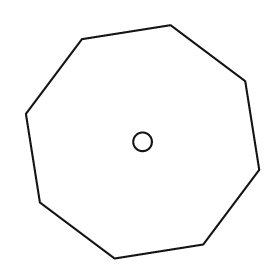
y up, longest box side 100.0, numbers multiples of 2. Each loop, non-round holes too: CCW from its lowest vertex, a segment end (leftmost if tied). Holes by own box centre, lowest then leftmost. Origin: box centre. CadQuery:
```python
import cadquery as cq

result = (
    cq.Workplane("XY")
    .moveTo(-12.0, -50.0)
    .lineTo(26.0, -44.0)
    .lineTo(50.0, -12.0)
    .lineTo(44.0, 26.0)
    .lineTo(12.0, 50.0)
    .lineTo(-26.0, 44.0)
    .lineTo(-50.0, 12.0)
    .lineTo(-44.0, -26.0)
    .close()
    .moveTo(0.0, 0.0)
    .circle(4.0)
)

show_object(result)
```